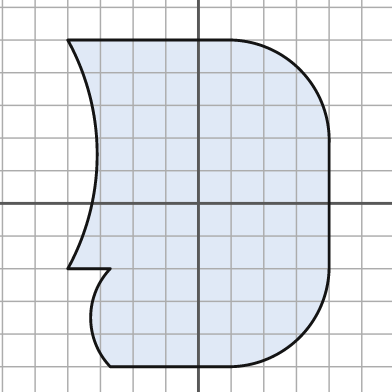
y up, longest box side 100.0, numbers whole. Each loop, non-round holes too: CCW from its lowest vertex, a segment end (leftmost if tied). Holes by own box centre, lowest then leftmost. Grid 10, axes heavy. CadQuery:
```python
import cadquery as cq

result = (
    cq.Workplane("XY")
    .moveTo(-27.0, -50.0)
    .lineTo(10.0, -50.0)
    .threePointArc((31.0, -41.0), (40.0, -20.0))
    .lineTo(40.0, 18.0)
    .threePointArc((31.0, 41.0), (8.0, 50.0))
    .lineTo(-40.0, 50.0)
    .threePointArc((-31.0, 15.0), (-40.0, -20.0))
    .lineTo(-27.0, -20.0)
    .threePointArc((-33.0, -35.0), (-27.0, -50.0))
    .close()
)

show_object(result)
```